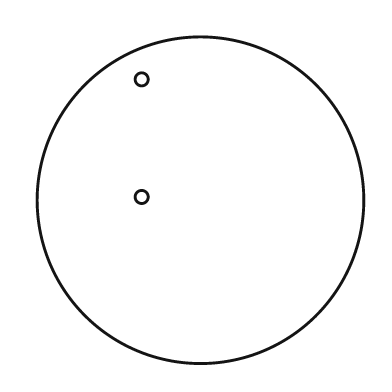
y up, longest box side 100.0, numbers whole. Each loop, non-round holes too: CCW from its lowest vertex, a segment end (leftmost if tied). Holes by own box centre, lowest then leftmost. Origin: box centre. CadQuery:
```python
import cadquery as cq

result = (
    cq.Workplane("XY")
    .moveTo(0.0, 0.0)
    .circle(50.0)
    .moveTo(-18.0, 1.0)
    .circle(2.0)
    .moveTo(-18.0, 37.0)
    .circle(2.0)
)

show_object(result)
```